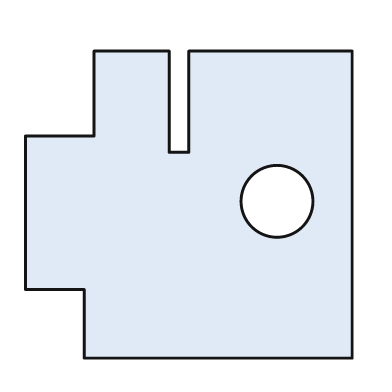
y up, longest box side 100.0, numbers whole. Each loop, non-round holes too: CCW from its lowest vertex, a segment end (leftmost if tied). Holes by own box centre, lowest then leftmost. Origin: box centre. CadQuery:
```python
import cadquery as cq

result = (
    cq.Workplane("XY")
    .moveTo(-32.0, -47.0)
    .lineTo(50.0, -47.0)
    .lineTo(50.0, 47.0)
    .lineTo(0.0, 47.0)
    .lineTo(0.0, 16.0)
    .lineTo(-6.0, 16.0)
    .lineTo(-6.0, 47.0)
    .lineTo(-29.0, 47.0)
    .lineTo(-29.0, 21.0)
    .lineTo(-50.0, 21.0)
    .lineTo(-50.0, -26.0)
    .lineTo(-32.0, -26.0)
    .close()
    .moveTo(27.0, 1.0)
    .circle(11.0)
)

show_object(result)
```